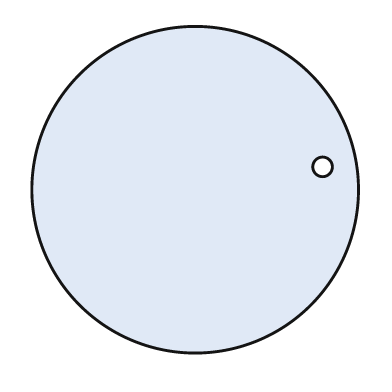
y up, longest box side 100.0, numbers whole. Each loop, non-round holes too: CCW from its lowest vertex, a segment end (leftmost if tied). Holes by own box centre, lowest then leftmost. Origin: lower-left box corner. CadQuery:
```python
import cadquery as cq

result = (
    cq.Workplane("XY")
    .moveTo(50.0, 50.0)
    .circle(50.0)
    .moveTo(89.0, 57.0)
    .circle(3.0)
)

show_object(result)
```